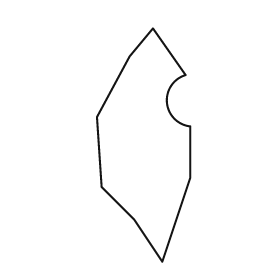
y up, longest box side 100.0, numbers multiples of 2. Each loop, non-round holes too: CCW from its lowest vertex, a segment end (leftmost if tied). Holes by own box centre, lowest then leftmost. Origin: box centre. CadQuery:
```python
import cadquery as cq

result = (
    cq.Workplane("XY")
    .moveTo(8.0, -50.0)
    .lineTo(20.0, -14.0)
    .lineTo(20.0, 8.0)
    .threePointArc((10.0, 18.0), (18.0, 30.0))
    .lineTo(4.0, 50.0)
    .lineTo(-6.0, 38.0)
    .lineTo(-20.0, 12.0)
    .lineTo(-18.0, -18.0)
    .lineTo(-4.0, -32.0)
    .close()
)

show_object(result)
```